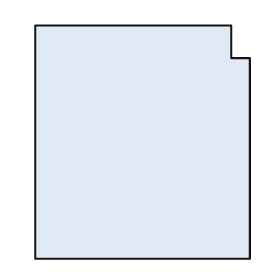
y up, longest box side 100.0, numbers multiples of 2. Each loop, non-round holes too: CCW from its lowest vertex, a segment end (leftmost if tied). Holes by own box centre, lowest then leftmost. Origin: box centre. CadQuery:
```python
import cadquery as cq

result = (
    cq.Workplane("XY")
    .moveTo(-46.0, -50.0)
    .lineTo(46.0, -50.0)
    .lineTo(46.0, 36.0)
    .lineTo(38.0, 36.0)
    .lineTo(38.0, 50.0)
    .lineTo(-46.0, 50.0)
    .close()
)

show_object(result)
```